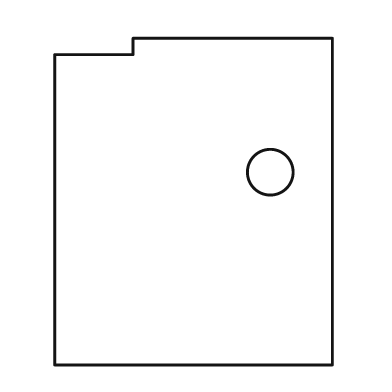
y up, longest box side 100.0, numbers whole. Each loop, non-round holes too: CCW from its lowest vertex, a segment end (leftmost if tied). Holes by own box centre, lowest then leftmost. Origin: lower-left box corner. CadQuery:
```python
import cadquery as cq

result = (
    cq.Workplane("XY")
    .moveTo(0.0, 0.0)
    .lineTo(85.0, 0.0)
    .lineTo(85.0, 100.0)
    .lineTo(24.0, 100.0)
    .lineTo(24.0, 95.0)
    .lineTo(0.0, 95.0)
    .close()
    .moveTo(66.0, 59.0)
    .circle(7.0)
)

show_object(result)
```